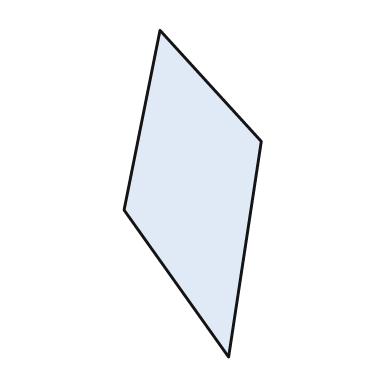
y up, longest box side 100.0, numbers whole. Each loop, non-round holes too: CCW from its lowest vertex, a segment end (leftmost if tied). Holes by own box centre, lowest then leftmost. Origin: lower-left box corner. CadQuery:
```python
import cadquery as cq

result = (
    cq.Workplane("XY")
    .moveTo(32.0, 0.0)
    .lineTo(42.0, 66.0)
    .lineTo(11.0, 100.0)
    .lineTo(0.0, 45.0)
    .close()
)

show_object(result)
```